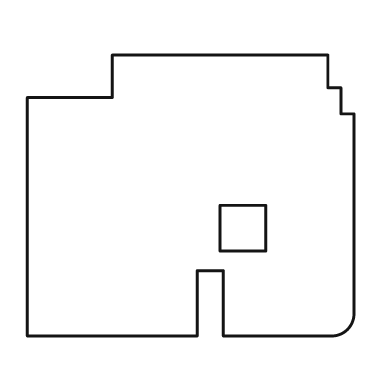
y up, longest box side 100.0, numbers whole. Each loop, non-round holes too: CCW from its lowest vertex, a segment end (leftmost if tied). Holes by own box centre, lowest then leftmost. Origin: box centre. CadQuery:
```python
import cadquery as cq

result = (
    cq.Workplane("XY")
    .moveTo(-50.0, -43.0)
    .lineTo(2.0, -43.0)
    .lineTo(2.0, -23.0)
    .lineTo(10.0, -23.0)
    .lineTo(10.0, -43.0)
    .lineTo(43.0, -43.0)
    .threePointArc((48.0, -41.0), (50.0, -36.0))
    .lineTo(50.0, 25.0)
    .lineTo(46.0, 25.0)
    .lineTo(46.0, 33.0)
    .lineTo(42.0, 33.0)
    .lineTo(42.0, 43.0)
    .lineTo(-24.0, 43.0)
    .lineTo(-24.0, 30.0)
    .lineTo(-50.0, 30.0)
    .close()
    .moveTo(9.0, -17.0)
    .lineTo(23.0, -17.0)
    .lineTo(23.0, -3.0)
    .lineTo(9.0, -3.0)
    .close()
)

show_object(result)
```